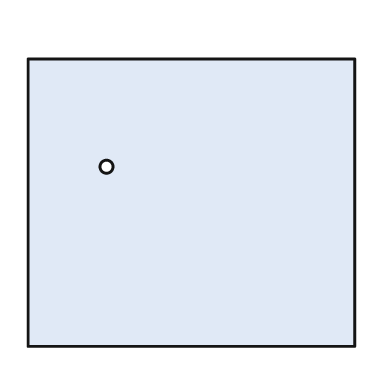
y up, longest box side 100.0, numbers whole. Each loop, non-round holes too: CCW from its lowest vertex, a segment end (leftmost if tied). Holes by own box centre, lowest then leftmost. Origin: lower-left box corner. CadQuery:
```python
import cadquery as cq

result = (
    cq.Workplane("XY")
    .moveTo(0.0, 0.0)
    .lineTo(100.0, 0.0)
    .lineTo(100.0, 88.0)
    .lineTo(0.0, 88.0)
    .close()
    .moveTo(24.0, 55.0)
    .circle(2.0)
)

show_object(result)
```